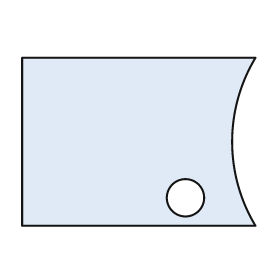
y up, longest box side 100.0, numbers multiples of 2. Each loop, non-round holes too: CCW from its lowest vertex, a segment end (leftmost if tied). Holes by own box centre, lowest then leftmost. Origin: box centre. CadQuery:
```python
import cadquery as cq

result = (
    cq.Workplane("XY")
    .moveTo(-50.0, -36.0)
    .lineTo(50.0, -36.0)
    .threePointArc((40.0, 0.0), (50.0, 36.0))
    .lineTo(-50.0, 36.0)
    .close()
    .moveTo(20.0, -24.0)
    .circle(8.0)
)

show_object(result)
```